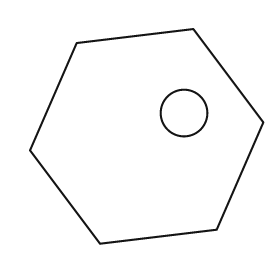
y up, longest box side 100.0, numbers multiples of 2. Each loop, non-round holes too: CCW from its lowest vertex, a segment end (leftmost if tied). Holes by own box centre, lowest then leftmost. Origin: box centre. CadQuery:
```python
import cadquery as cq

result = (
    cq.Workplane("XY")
    .moveTo(-20.0, -46.0)
    .lineTo(30.0, -40.0)
    .lineTo(50.0, 6.0)
    .lineTo(20.0, 46.0)
    .lineTo(-30.0, 40.0)
    .lineTo(-50.0, -6.0)
    .close()
    .moveTo(16.0, 10.0)
    .circle(10.0)
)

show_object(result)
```